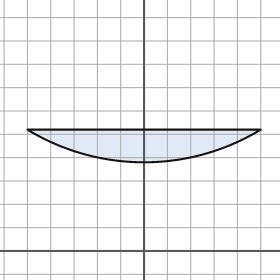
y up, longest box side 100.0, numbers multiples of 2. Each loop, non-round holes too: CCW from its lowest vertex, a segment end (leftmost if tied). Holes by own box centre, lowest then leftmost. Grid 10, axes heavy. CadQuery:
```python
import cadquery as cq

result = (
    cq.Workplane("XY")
    .moveTo(-50.0, 52.0)
    .threePointArc((0.0, 38.0), (50.0, 52.0))
    .close()
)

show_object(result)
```